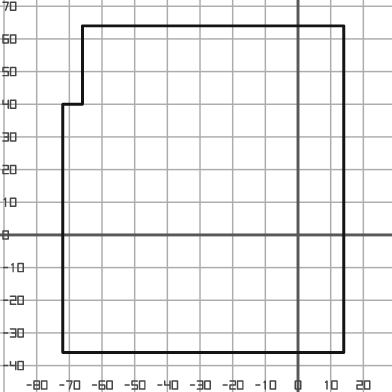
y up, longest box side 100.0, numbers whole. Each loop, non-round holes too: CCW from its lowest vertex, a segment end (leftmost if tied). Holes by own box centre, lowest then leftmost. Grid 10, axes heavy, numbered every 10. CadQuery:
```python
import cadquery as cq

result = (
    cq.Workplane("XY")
    .moveTo(-72.0, -36.0)
    .lineTo(14.0, -36.0)
    .lineTo(14.0, 64.0)
    .lineTo(-66.0, 64.0)
    .lineTo(-66.0, 40.0)
    .lineTo(-72.0, 40.0)
    .close()
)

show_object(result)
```